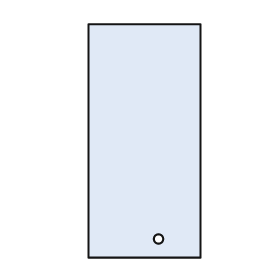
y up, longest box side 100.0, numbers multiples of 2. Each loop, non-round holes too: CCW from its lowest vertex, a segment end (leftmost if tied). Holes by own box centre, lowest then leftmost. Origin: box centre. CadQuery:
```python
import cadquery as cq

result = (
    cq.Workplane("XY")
    .moveTo(-24.0, -50.0)
    .lineTo(24.0, -50.0)
    .lineTo(24.0, 50.0)
    .lineTo(-24.0, 50.0)
    .close()
    .moveTo(6.0, -42.0)
    .circle(2.0)
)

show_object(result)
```